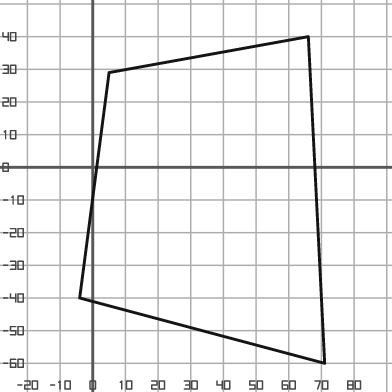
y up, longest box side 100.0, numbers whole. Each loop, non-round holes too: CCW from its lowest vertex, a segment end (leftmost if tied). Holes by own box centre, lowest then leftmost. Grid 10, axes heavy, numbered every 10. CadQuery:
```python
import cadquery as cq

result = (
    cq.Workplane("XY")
    .moveTo(71.0, -60.0)
    .lineTo(66.0, 40.0)
    .lineTo(5.0, 29.0)
    .lineTo(-4.0, -40.0)
    .close()
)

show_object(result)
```